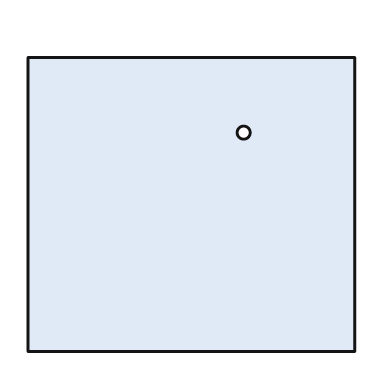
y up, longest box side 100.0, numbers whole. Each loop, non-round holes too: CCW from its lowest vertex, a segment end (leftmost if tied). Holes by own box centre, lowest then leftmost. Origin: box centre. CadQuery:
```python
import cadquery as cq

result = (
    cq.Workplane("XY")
    .moveTo(-50.0, -45.0)
    .lineTo(50.0, -45.0)
    .lineTo(50.0, 45.0)
    .lineTo(-50.0, 45.0)
    .close()
    .moveTo(16.0, 22.0)
    .circle(2.0)
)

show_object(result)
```